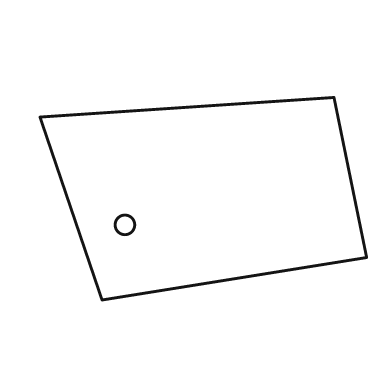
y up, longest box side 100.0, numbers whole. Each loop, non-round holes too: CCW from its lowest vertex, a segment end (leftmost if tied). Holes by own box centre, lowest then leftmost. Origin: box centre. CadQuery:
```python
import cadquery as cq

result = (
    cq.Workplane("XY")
    .moveTo(-31.0, -31.0)
    .lineTo(50.0, -18.0)
    .lineTo(40.0, 31.0)
    .lineTo(-50.0, 25.0)
    .close()
    .moveTo(-24.0, -8.0)
    .circle(3.0)
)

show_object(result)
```